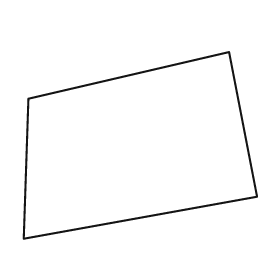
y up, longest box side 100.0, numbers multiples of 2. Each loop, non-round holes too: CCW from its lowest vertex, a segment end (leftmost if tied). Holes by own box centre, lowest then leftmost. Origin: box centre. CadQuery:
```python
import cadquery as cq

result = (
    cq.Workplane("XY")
    .moveTo(-50.0, -40.0)
    .lineTo(50.0, -22.0)
    .lineTo(38.0, 40.0)
    .lineTo(-48.0, 20.0)
    .close()
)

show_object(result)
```